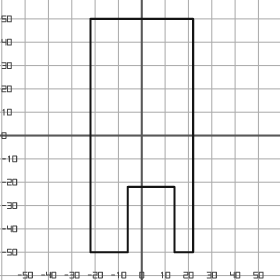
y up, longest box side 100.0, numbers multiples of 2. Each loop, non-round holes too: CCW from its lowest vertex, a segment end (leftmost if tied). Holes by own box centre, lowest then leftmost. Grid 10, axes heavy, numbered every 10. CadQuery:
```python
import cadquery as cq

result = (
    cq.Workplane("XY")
    .moveTo(-22.0, -50.0)
    .lineTo(-6.0, -50.0)
    .lineTo(-6.0, -22.0)
    .lineTo(14.0, -22.0)
    .lineTo(14.0, -50.0)
    .lineTo(22.0, -50.0)
    .lineTo(22.0, 50.0)
    .lineTo(-22.0, 50.0)
    .close()
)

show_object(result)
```